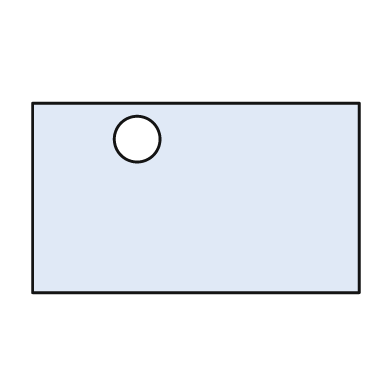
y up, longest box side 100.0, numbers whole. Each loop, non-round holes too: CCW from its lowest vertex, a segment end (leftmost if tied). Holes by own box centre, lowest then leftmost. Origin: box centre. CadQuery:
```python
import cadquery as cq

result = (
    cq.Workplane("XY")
    .moveTo(-50.0, -29.0)
    .lineTo(50.0, -29.0)
    .lineTo(50.0, 29.0)
    .lineTo(-50.0, 29.0)
    .close()
    .moveTo(-18.0, 18.0)
    .circle(7.0)
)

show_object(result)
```